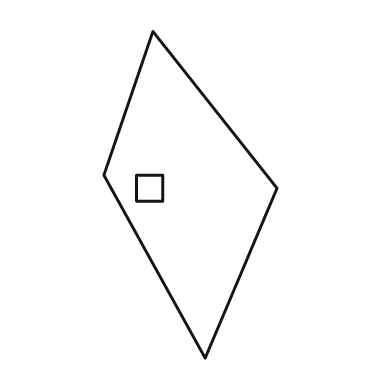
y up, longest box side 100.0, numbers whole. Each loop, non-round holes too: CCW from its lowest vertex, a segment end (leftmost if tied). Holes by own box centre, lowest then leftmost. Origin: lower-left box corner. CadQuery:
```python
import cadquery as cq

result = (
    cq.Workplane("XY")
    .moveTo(31.0, 0.0)
    .lineTo(53.0, 52.0)
    .lineTo(15.0, 100.0)
    .lineTo(0.0, 56.0)
    .close()
    .moveTo(10.0, 48.0)
    .lineTo(18.0, 48.0)
    .lineTo(18.0, 56.0)
    .lineTo(10.0, 56.0)
    .close()
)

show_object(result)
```